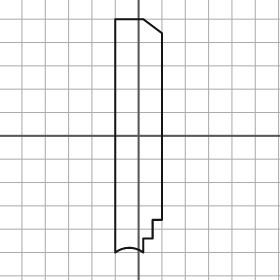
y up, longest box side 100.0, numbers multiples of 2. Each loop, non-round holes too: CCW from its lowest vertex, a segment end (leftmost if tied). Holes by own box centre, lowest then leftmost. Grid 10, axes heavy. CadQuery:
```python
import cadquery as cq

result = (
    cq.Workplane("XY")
    .moveTo(-10.0, -50.0)
    .threePointArc((-4.0, -48.0), (2.0, -50.0))
    .lineTo(2.0, -44.0)
    .lineTo(6.0, -44.0)
    .lineTo(6.0, -36.0)
    .lineTo(10.0, -36.0)
    .lineTo(10.0, 44.0)
    .lineTo(2.0, 50.0)
    .lineTo(-10.0, 50.0)
    .close()
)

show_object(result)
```